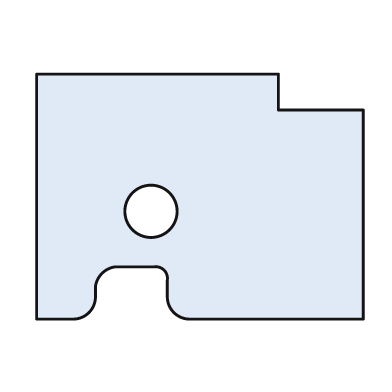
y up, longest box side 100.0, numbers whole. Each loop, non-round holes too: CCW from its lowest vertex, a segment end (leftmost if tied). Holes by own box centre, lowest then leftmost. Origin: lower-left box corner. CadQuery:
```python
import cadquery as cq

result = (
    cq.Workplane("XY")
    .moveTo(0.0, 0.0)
    .lineTo(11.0, 0.0)
    .threePointArc((16.0, 2.0), (18.0, 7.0))
    .lineTo(18.0, 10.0)
    .threePointArc((20.0, 14.0), (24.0, 16.0))
    .lineTo(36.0, 16.0)
    .threePointArc((39.0, 15.0), (40.0, 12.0))
    .lineTo(40.0, 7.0)
    .threePointArc((42.0, 2.0), (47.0, 0.0))
    .lineTo(100.0, 0.0)
    .lineTo(100.0, 64.0)
    .lineTo(74.0, 64.0)
    .lineTo(74.0, 75.0)
    .lineTo(0.0, 75.0)
    .close()
    .moveTo(35.0, 33.0)
    .circle(8.0)
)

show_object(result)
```